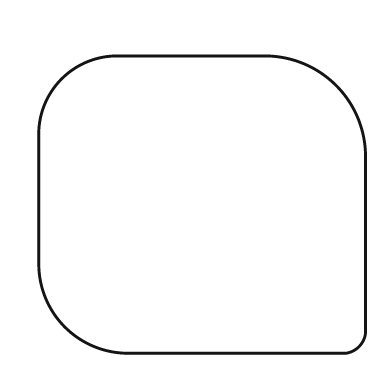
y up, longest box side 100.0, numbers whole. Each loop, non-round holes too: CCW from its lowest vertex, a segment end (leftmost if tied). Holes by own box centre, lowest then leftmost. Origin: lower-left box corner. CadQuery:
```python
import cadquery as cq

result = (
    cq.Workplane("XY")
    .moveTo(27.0, 0.0)
    .lineTo(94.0, 0.0)
    .threePointArc((98.0, 2.0), (100.0, 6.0))
    .lineTo(100.0, 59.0)
    .threePointArc((91.0, 82.0), (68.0, 91.0))
    .lineTo(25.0, 91.0)
    .threePointArc((7.0, 84.0), (0.0, 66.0))
    .lineTo(0.0, 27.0)
    .threePointArc((8.0, 8.0), (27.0, 0.0))
    .close()
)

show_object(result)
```